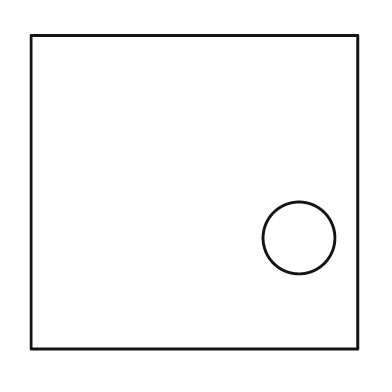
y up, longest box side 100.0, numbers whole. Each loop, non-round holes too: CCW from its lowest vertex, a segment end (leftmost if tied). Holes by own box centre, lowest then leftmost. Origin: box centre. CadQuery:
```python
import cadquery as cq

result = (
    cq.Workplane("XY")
    .moveTo(-50.0, -48.0)
    .lineTo(50.0, -48.0)
    .lineTo(50.0, 48.0)
    .lineTo(-50.0, 48.0)
    .close()
    .moveTo(32.0, -14.0)
    .circle(11.0)
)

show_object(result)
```